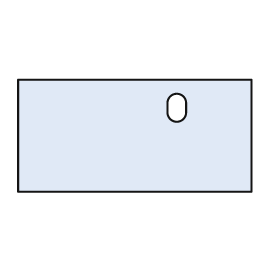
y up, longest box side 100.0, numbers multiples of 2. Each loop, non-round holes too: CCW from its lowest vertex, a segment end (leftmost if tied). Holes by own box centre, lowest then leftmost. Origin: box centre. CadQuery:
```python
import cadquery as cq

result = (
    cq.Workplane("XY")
    .moveTo(-50.0, -24.0)
    .lineTo(50.0, -24.0)
    .lineTo(50.0, 24.0)
    .lineTo(-50.0, 24.0)
    .close()
    .moveTo(14.0, 10.0)
    .threePointArc((18.0, 6.0), (22.0, 10.0))
    .lineTo(22.0, 14.0)
    .threePointArc((18.0, 18.0), (14.0, 14.0))
    .close()
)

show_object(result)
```